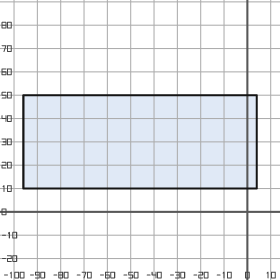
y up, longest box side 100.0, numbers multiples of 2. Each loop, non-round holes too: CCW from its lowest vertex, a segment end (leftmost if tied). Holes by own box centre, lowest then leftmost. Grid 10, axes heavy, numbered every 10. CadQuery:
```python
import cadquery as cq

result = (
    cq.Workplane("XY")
    .moveTo(-96.0, 10.0)
    .lineTo(4.0, 10.0)
    .lineTo(4.0, 50.0)
    .lineTo(-96.0, 50.0)
    .close()
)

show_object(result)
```